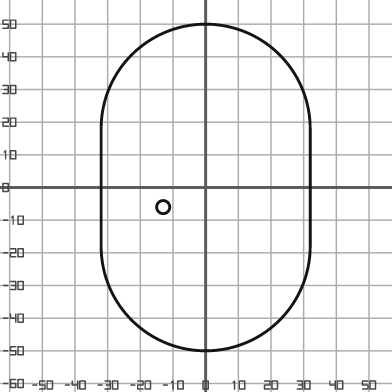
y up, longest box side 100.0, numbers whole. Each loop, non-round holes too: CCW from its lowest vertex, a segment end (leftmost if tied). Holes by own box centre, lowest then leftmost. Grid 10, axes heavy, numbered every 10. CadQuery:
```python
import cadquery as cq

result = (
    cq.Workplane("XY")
    .moveTo(-32.0, -18.0)
    .threePointArc((0.0, -50.0), (32.0, -18.0))
    .lineTo(32.0, 18.0)
    .threePointArc((0.0, 50.0), (-32.0, 18.0))
    .close()
    .moveTo(-13.0, -6.0)
    .circle(2.0)
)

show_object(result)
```